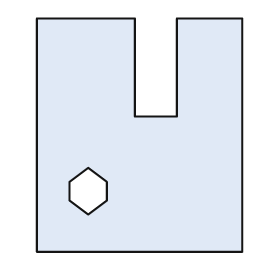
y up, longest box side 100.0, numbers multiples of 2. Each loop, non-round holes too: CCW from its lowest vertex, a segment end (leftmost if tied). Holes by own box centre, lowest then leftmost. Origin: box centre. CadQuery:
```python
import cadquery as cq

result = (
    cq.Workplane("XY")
    .moveTo(-44.0, -50.0)
    .lineTo(44.0, -50.0)
    .lineTo(44.0, 50.0)
    .lineTo(16.0, 50.0)
    .lineTo(16.0, 8.0)
    .lineTo(-2.0, 8.0)
    .lineTo(-2.0, 50.0)
    .lineTo(-44.0, 50.0)
    .close()
    .moveTo(-22.0, -34.0)
    .lineTo(-14.0, -28.0)
    .lineTo(-14.0, -20.0)
    .lineTo(-22.0, -14.0)
    .lineTo(-30.0, -20.0)
    .lineTo(-30.0, -28.0)
    .close()
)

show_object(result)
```